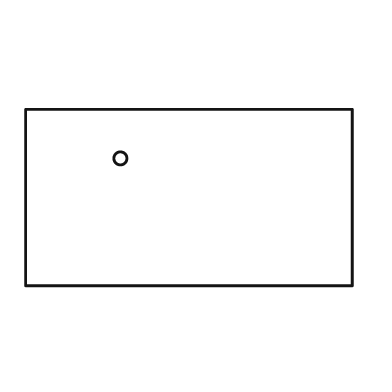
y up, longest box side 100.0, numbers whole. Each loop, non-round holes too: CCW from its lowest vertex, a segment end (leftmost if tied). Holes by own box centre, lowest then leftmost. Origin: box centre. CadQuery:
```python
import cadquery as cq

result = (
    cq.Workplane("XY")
    .moveTo(-50.0, -27.0)
    .lineTo(50.0, -27.0)
    .lineTo(50.0, 27.0)
    .lineTo(-50.0, 27.0)
    .close()
    .moveTo(-21.0, 12.0)
    .circle(2.0)
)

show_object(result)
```